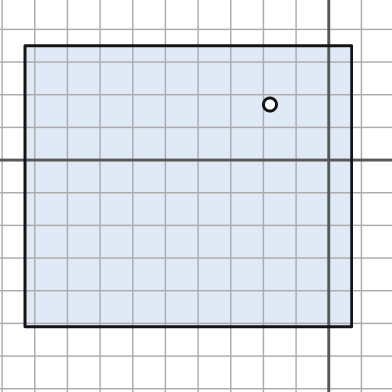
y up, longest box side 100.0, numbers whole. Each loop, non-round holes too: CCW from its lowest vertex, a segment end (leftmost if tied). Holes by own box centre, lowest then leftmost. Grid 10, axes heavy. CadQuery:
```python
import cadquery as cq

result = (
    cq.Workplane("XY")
    .moveTo(-93.0, -51.0)
    .lineTo(7.0, -51.0)
    .lineTo(7.0, 35.0)
    .lineTo(-93.0, 35.0)
    .close()
    .moveTo(-18.0, 17.0)
    .circle(2.0)
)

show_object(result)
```